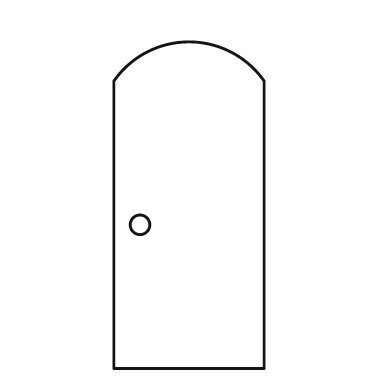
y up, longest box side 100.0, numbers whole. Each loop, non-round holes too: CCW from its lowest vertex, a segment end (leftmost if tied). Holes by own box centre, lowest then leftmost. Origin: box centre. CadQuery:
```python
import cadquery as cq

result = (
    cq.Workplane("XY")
    .moveTo(-23.0, -50.0)
    .lineTo(23.0, -50.0)
    .lineTo(23.0, 38.0)
    .threePointArc((0.0, 50.0), (-23.0, 38.0))
    .close()
    .moveTo(-15.0, -6.0)
    .circle(3.0)
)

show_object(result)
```